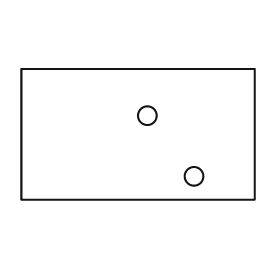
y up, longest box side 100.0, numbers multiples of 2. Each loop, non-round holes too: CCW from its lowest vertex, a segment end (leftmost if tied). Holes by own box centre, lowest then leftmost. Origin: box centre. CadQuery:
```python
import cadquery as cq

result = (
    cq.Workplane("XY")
    .moveTo(-50.0, -28.0)
    .lineTo(50.0, -28.0)
    .lineTo(50.0, 28.0)
    .lineTo(-50.0, 28.0)
    .close()
    .moveTo(24.0, -18.0)
    .circle(4.0)
    .moveTo(4.0, 8.0)
    .circle(4.0)
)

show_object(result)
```